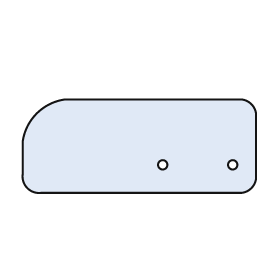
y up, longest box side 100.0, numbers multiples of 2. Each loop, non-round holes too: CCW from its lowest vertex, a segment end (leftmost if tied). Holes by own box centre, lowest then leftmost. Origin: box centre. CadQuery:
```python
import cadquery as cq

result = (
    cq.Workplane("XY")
    .moveTo(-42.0, -20.0)
    .lineTo(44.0, -20.0)
    .threePointArc((48.0, -18.0), (50.0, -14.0))
    .lineTo(50.0, 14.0)
    .threePointArc((48.0, 18.0), (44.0, 20.0))
    .lineTo(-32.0, 20.0)
    .threePointArc((-44.0, 14.0), (-50.0, 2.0))
    .lineTo(-50.0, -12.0)
    .threePointArc((-48.0, -18.0), (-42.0, -20.0))
    .close()
    .moveTo(10.0, -8.0)
    .circle(2.0)
    .moveTo(40.0, -8.0)
    .circle(2.0)
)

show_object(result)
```